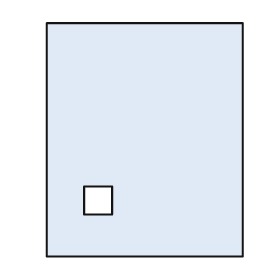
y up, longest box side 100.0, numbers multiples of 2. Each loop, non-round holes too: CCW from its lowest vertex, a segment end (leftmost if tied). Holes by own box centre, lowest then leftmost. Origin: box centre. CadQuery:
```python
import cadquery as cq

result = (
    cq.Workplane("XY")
    .moveTo(-42.0, -50.0)
    .lineTo(42.0, -50.0)
    .lineTo(42.0, 50.0)
    .lineTo(-42.0, 50.0)
    .close()
    .moveTo(-26.0, -32.0)
    .lineTo(-14.0, -32.0)
    .lineTo(-14.0, -20.0)
    .lineTo(-26.0, -20.0)
    .close()
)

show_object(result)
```